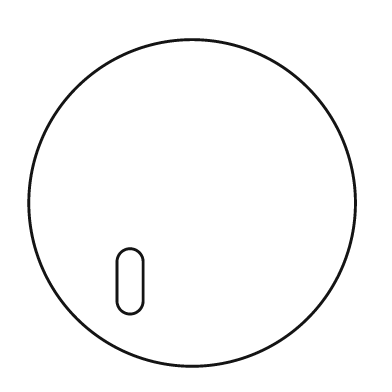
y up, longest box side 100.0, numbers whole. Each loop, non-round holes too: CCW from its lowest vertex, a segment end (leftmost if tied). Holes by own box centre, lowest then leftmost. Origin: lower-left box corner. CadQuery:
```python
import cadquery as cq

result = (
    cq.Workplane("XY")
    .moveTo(50.0, 50.0)
    .circle(50.0)
    .moveTo(27.0, 20.0)
    .threePointArc((31.0, 16.0), (35.0, 20.0))
    .lineTo(35.0, 32.0)
    .threePointArc((31.0, 36.0), (27.0, 32.0))
    .close()
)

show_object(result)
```